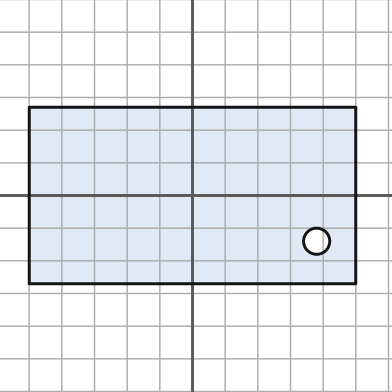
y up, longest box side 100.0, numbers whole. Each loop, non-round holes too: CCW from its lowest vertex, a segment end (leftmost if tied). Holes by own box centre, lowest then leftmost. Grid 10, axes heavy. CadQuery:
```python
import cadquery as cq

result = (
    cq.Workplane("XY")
    .moveTo(-50.0, -27.0)
    .lineTo(50.0, -27.0)
    .lineTo(50.0, 27.0)
    .lineTo(-50.0, 27.0)
    .close()
    .moveTo(38.0, -14.0)
    .circle(4.0)
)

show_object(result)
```